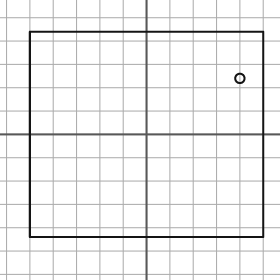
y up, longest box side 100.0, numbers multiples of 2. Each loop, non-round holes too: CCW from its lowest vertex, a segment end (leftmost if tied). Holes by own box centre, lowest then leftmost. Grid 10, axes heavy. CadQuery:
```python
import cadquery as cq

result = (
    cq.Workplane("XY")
    .moveTo(-50.0, -44.0)
    .lineTo(50.0, -44.0)
    .lineTo(50.0, 44.0)
    .lineTo(-50.0, 44.0)
    .close()
    .moveTo(40.0, 24.0)
    .circle(2.0)
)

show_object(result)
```